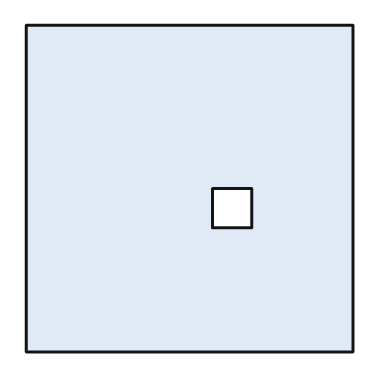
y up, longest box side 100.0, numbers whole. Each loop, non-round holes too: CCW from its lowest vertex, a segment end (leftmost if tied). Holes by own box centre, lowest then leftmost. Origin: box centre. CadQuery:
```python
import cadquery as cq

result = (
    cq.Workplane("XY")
    .moveTo(-50.0, -50.0)
    .lineTo(50.0, -50.0)
    .lineTo(50.0, 50.0)
    .lineTo(-50.0, 50.0)
    .close()
    .moveTo(7.0, -12.0)
    .lineTo(19.0, -12.0)
    .lineTo(19.0, 0.0)
    .lineTo(7.0, 0.0)
    .close()
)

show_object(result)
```